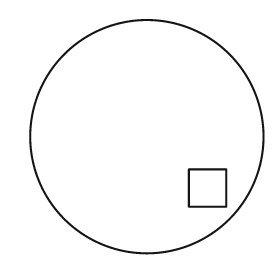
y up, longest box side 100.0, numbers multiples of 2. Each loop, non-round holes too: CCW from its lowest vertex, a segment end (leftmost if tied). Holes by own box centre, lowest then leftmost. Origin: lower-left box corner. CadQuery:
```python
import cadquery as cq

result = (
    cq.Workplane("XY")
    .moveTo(50.0, 50.0)
    .circle(50.0)
    .moveTo(68.0, 20.0)
    .lineTo(84.0, 20.0)
    .lineTo(84.0, 36.0)
    .lineTo(68.0, 36.0)
    .close()
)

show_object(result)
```